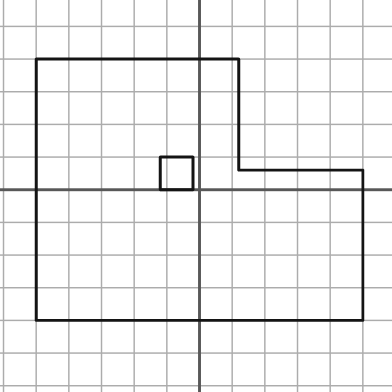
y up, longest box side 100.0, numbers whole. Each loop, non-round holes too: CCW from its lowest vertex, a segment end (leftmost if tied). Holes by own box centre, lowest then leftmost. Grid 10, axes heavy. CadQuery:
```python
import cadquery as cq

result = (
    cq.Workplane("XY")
    .moveTo(-50.0, -40.0)
    .lineTo(50.0, -40.0)
    .lineTo(50.0, 6.0)
    .lineTo(12.0, 6.0)
    .lineTo(12.0, 40.0)
    .lineTo(-50.0, 40.0)
    .close()
    .moveTo(-12.0, 0.0)
    .lineTo(-2.0, 0.0)
    .lineTo(-2.0, 10.0)
    .lineTo(-12.0, 10.0)
    .close()
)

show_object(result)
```